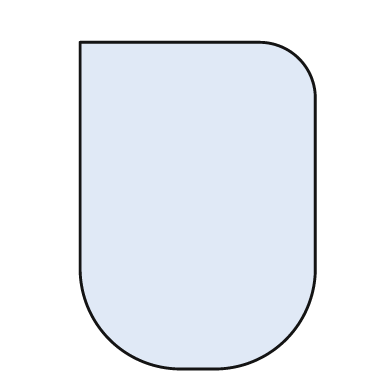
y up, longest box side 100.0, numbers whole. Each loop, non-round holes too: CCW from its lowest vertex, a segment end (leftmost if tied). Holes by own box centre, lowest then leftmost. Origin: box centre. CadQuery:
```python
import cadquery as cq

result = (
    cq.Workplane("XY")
    .moveTo(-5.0, -50.0)
    .lineTo(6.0, -50.0)
    .threePointArc((27.0, -41.0), (36.0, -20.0))
    .lineTo(36.0, 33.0)
    .threePointArc((31.0, 45.0), (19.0, 50.0))
    .lineTo(-36.0, 50.0)
    .lineTo(-36.0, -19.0)
    .threePointArc((-27.0, -41.0), (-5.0, -50.0))
    .close()
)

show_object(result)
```